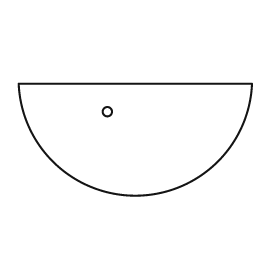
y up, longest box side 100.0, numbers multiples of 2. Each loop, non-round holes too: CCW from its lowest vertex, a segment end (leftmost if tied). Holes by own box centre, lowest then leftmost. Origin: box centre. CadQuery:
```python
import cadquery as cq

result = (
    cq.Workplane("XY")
    .moveTo(-50.0, 24.0)
    .threePointArc((0.0, -24.0), (50.0, 24.0))
    .close()
    .moveTo(-12.0, 12.0)
    .circle(2.0)
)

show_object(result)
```